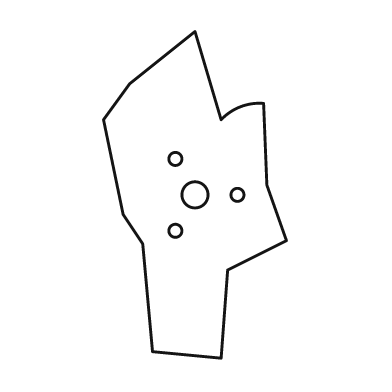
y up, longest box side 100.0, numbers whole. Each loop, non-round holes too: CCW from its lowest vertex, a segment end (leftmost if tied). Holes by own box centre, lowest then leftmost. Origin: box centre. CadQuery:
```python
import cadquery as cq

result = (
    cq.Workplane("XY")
    .moveTo(8.0, -50.0)
    .lineTo(10.0, -23.0)
    .lineTo(28.0, -14.0)
    .lineTo(22.0, 3.0)
    .lineTo(21.0, 28.0)
    .threePointArc((14.0, 27.0), (8.0, 23.0))
    .lineTo(0.0, 50.0)
    .lineTo(-20.0, 34.0)
    .lineTo(-28.0, 23.0)
    .lineTo(-22.0, -6.0)
    .lineTo(-16.0, -15.0)
    .lineTo(-13.0, -48.0)
    .close()
    .moveTo(-6.0, -11.0)
    .circle(2.0)
    .moveTo(0.0, 0.0)
    .circle(4.0)
    .moveTo(13.0, 0.0)
    .circle(2.0)
    .moveTo(-6.0, 11.0)
    .circle(2.0)
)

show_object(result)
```